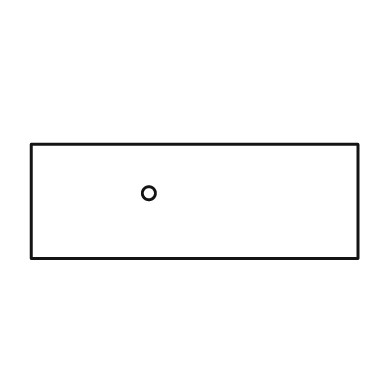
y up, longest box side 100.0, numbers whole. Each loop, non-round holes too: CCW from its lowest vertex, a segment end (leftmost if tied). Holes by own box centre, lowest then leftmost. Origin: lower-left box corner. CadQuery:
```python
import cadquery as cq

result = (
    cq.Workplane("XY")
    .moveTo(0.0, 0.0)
    .lineTo(100.0, 0.0)
    .lineTo(100.0, 35.0)
    .lineTo(0.0, 35.0)
    .close()
    .moveTo(36.0, 20.0)
    .circle(2.0)
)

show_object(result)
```